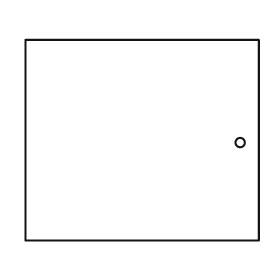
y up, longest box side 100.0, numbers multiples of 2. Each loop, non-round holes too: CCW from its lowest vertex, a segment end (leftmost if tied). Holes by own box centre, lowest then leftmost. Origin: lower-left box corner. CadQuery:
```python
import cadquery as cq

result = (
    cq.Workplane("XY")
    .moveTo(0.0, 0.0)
    .lineTo(100.0, 0.0)
    .lineTo(100.0, 86.0)
    .lineTo(0.0, 86.0)
    .close()
    .moveTo(92.0, 42.0)
    .circle(2.0)
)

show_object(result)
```